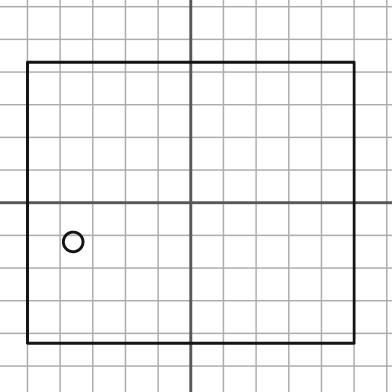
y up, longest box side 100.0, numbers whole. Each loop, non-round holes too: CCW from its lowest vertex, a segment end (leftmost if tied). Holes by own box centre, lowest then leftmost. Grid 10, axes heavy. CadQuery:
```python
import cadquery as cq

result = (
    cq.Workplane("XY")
    .moveTo(-50.0, -43.0)
    .lineTo(50.0, -43.0)
    .lineTo(50.0, 43.0)
    .lineTo(-50.0, 43.0)
    .close()
    .moveTo(-36.0, -12.0)
    .circle(3.0)
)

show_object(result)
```